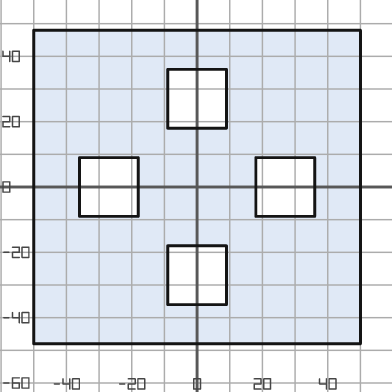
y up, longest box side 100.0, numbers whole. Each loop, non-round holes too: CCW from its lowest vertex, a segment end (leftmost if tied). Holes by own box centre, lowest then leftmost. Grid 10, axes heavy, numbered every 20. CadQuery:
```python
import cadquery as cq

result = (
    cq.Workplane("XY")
    .moveTo(-50.0, -48.0)
    .lineTo(50.0, -48.0)
    .lineTo(50.0, 48.0)
    .lineTo(-50.0, 48.0)
    .close()
    .moveTo(-9.0, -36.0)
    .lineTo(9.0, -36.0)
    .lineTo(9.0, -18.0)
    .lineTo(-9.0, -18.0)
    .close()
    .moveTo(-36.0, -9.0)
    .lineTo(-18.0, -9.0)
    .lineTo(-18.0, 9.0)
    .lineTo(-36.0, 9.0)
    .close()
    .moveTo(18.0, -9.0)
    .lineTo(36.0, -9.0)
    .lineTo(36.0, 9.0)
    .lineTo(18.0, 9.0)
    .close()
    .moveTo(-9.0, 18.0)
    .lineTo(9.0, 18.0)
    .lineTo(9.0, 36.0)
    .lineTo(-9.0, 36.0)
    .close()
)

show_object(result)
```